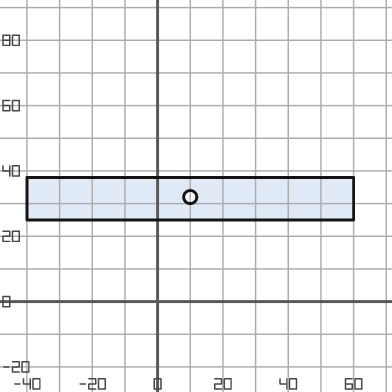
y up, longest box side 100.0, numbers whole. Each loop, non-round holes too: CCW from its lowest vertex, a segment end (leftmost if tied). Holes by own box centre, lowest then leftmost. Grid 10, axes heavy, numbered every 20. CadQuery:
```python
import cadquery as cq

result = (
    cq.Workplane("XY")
    .moveTo(-40.0, 25.0)
    .lineTo(60.0, 25.0)
    .lineTo(60.0, 38.0)
    .lineTo(-40.0, 38.0)
    .close()
    .moveTo(10.0, 32.0)
    .circle(2.0)
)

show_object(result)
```